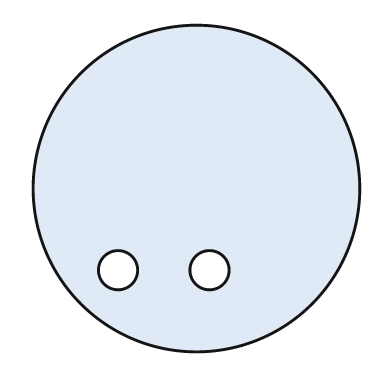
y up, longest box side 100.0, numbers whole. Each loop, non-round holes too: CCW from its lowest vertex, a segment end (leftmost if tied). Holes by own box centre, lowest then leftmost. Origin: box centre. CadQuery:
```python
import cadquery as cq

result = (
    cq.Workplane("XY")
    .moveTo(0.0, 0.0)
    .circle(50.0)
    .moveTo(-24.0, -25.0)
    .circle(6.0)
    .moveTo(4.0, -25.0)
    .circle(6.0)
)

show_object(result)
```